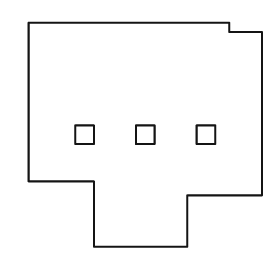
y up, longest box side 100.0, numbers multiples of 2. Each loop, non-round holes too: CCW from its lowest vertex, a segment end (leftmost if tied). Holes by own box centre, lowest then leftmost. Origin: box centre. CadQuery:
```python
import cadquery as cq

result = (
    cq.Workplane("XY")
    .moveTo(-22.0, -48.0)
    .lineTo(18.0, -48.0)
    .lineTo(18.0, -26.0)
    .lineTo(50.0, -26.0)
    .lineTo(50.0, 44.0)
    .lineTo(36.0, 44.0)
    .lineTo(36.0, 48.0)
    .lineTo(-50.0, 48.0)
    .lineTo(-50.0, -20.0)
    .lineTo(-22.0, -20.0)
    .close()
    .moveTo(-30.0, -4.0)
    .lineTo(-22.0, -4.0)
    .lineTo(-22.0, 4.0)
    .lineTo(-30.0, 4.0)
    .close()
    .moveTo(-4.0, -4.0)
    .lineTo(4.0, -4.0)
    .lineTo(4.0, 4.0)
    .lineTo(-4.0, 4.0)
    .close()
    .moveTo(22.0, -4.0)
    .lineTo(30.0, -4.0)
    .lineTo(30.0, 4.0)
    .lineTo(22.0, 4.0)
    .close()
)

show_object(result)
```